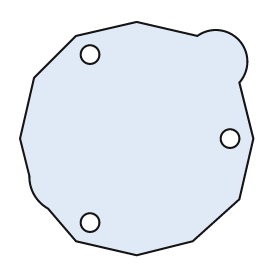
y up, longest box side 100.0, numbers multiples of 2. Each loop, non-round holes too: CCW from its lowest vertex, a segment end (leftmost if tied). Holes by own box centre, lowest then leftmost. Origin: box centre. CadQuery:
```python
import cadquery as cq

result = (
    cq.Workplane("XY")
    .moveTo(0.0, -50.0)
    .lineTo(24.0, -44.0)
    .lineTo(44.0, -26.0)
    .lineTo(50.0, 0.0)
    .lineTo(44.0, 24.0)
    .threePointArc((44.0, 42.0), (26.0, 44.0))
    .lineTo(0.0, 50.0)
    .lineTo(-26.0, 44.0)
    .lineTo(-44.0, 26.0)
    .lineTo(-50.0, 0.0)
    .lineTo(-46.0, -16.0)
    .threePointArc((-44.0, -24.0), (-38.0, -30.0))
    .lineTo(-26.0, -44.0)
    .close()
    .moveTo(-20.0, -36.0)
    .circle(4.0)
    .moveTo(40.0, 0.0)
    .circle(4.0)
    .moveTo(-20.0, 36.0)
    .circle(4.0)
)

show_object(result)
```